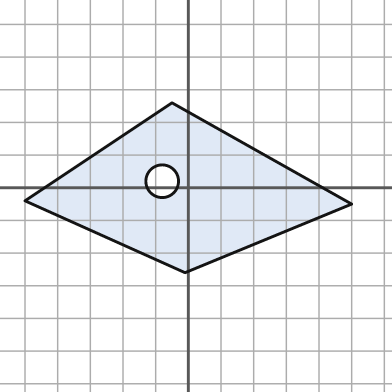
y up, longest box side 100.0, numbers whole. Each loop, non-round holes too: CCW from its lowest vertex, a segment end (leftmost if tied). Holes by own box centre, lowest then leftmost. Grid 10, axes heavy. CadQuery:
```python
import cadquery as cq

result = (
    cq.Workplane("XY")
    .moveTo(-1.0, -26.0)
    .lineTo(50.0, -5.0)
    .lineTo(-5.0, 26.0)
    .lineTo(-50.0, -4.0)
    .close()
    .moveTo(-8.0, 2.0)
    .circle(5.0)
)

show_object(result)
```